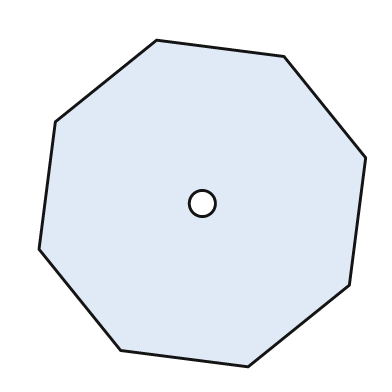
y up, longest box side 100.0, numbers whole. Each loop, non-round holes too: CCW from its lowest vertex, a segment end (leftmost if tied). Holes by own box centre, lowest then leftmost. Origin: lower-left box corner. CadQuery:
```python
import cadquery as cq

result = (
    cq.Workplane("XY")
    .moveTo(64.0, 0.0)
    .lineTo(95.0, 25.0)
    .lineTo(100.0, 64.0)
    .lineTo(75.0, 95.0)
    .lineTo(36.0, 100.0)
    .lineTo(5.0, 75.0)
    .lineTo(0.0, 36.0)
    .lineTo(25.0, 5.0)
    .close()
    .moveTo(50.0, 50.0)
    .circle(4.0)
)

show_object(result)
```